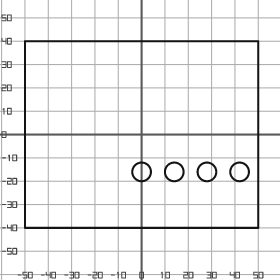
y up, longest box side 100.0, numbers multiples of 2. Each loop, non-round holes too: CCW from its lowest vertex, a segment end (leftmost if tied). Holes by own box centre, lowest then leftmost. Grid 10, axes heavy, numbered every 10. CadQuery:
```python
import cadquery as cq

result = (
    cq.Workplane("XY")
    .moveTo(-50.0, -40.0)
    .lineTo(50.0, -40.0)
    .lineTo(50.0, 40.0)
    .lineTo(-50.0, 40.0)
    .close()
    .moveTo(0.0, -16.0)
    .circle(4.0)
    .moveTo(14.0, -16.0)
    .circle(4.0)
    .moveTo(28.0, -16.0)
    .circle(4.0)
    .moveTo(42.0, -16.0)
    .circle(4.0)
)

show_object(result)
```